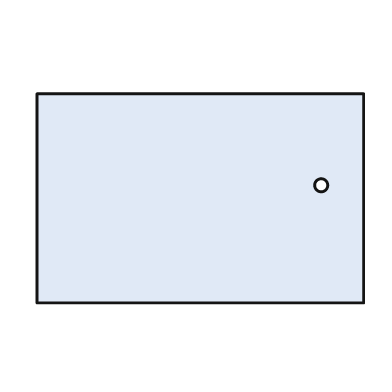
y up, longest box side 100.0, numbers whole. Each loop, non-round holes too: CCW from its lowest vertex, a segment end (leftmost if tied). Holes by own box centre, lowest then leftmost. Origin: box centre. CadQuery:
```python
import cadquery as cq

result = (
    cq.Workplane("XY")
    .moveTo(-50.0, -32.0)
    .lineTo(50.0, -32.0)
    .lineTo(50.0, 32.0)
    .lineTo(-50.0, 32.0)
    .close()
    .moveTo(37.0, 4.0)
    .circle(2.0)
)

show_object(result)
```